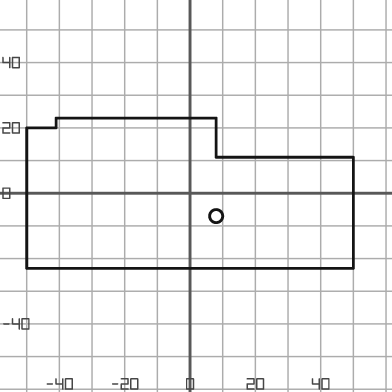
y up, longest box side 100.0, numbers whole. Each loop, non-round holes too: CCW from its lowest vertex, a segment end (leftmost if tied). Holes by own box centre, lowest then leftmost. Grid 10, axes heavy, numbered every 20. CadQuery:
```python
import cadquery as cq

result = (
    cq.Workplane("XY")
    .moveTo(-50.0, -23.0)
    .lineTo(50.0, -23.0)
    .lineTo(50.0, 11.0)
    .lineTo(8.0, 11.0)
    .lineTo(8.0, 23.0)
    .lineTo(-41.0, 23.0)
    .lineTo(-41.0, 20.0)
    .lineTo(-50.0, 20.0)
    .close()
    .moveTo(8.0, -7.0)
    .circle(2.0)
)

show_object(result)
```